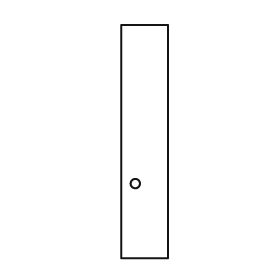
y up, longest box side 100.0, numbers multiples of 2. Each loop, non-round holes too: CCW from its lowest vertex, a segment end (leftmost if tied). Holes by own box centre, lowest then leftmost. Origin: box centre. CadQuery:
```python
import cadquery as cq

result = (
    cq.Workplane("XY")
    .moveTo(-10.0, -50.0)
    .lineTo(10.0, -50.0)
    .lineTo(10.0, 50.0)
    .lineTo(-10.0, 50.0)
    .close()
    .moveTo(-4.0, -18.0)
    .circle(2.0)
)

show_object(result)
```